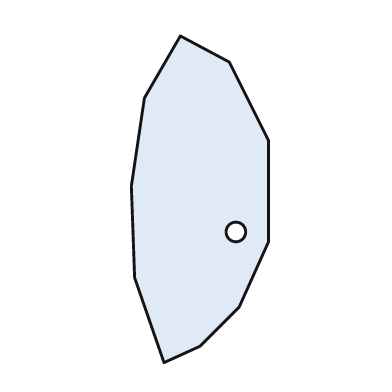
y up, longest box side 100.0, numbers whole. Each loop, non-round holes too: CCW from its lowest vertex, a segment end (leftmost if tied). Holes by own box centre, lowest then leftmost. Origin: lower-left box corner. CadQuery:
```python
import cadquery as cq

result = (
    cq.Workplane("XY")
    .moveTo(10.0, 0.0)
    .lineTo(21.0, 5.0)
    .lineTo(33.0, 17.0)
    .lineTo(42.0, 37.0)
    .lineTo(42.0, 68.0)
    .lineTo(30.0, 92.0)
    .lineTo(15.0, 100.0)
    .lineTo(4.0, 81.0)
    .lineTo(0.0, 54.0)
    .lineTo(1.0, 26.0)
    .close()
    .moveTo(32.0, 40.0)
    .circle(3.0)
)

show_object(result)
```